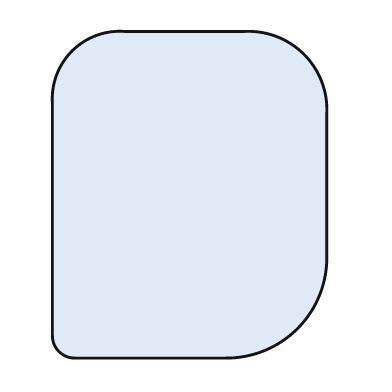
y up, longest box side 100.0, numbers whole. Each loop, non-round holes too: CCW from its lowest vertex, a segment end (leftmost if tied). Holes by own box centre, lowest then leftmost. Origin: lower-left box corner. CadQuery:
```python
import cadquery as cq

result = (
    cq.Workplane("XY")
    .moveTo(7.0, 0.0)
    .lineTo(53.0, 0.0)
    .threePointArc((75.0, 9.0), (84.0, 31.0))
    .lineTo(84.0, 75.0)
    .threePointArc((77.0, 93.0), (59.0, 100.0))
    .lineTo(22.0, 100.0)
    .threePointArc((6.0, 94.0), (0.0, 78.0))
    .lineTo(0.0, 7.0)
    .threePointArc((2.0, 2.0), (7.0, 0.0))
    .close()
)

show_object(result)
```